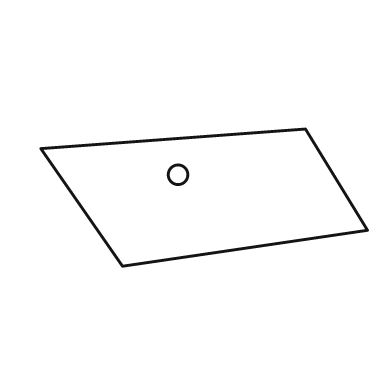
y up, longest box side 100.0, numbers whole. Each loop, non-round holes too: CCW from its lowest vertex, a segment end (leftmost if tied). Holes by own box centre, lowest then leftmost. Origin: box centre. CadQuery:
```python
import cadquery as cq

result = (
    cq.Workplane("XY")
    .moveTo(-25.0, -21.0)
    .lineTo(50.0, -10.0)
    .lineTo(31.0, 21.0)
    .lineTo(-50.0, 15.0)
    .close()
    .moveTo(-8.0, 7.0)
    .circle(3.0)
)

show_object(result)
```